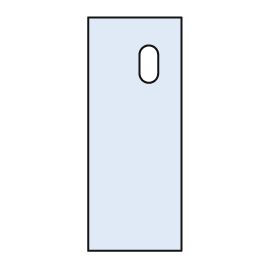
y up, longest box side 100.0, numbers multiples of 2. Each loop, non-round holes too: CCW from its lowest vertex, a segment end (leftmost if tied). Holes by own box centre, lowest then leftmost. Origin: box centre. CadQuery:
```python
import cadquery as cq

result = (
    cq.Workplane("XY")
    .moveTo(-20.0, -50.0)
    .lineTo(20.0, -50.0)
    .lineTo(20.0, 50.0)
    .lineTo(-20.0, 50.0)
    .close()
    .moveTo(2.0, 26.0)
    .threePointArc((6.0, 22.0), (10.0, 26.0))
    .lineTo(10.0, 34.0)
    .threePointArc((6.0, 38.0), (2.0, 34.0))
    .close()
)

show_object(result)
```